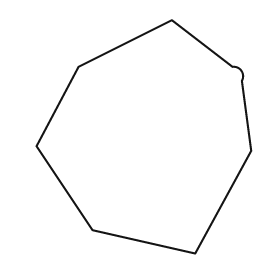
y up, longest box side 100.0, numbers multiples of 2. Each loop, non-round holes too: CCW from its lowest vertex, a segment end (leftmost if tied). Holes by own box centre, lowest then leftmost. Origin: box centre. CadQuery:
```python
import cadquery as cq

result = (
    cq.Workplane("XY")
    .moveTo(22.0, -50.0)
    .lineTo(46.0, -6.0)
    .lineTo(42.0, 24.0)
    .threePointArc((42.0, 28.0), (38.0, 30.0))
    .lineTo(12.0, 50.0)
    .lineTo(-28.0, 30.0)
    .lineTo(-46.0, -4.0)
    .lineTo(-22.0, -40.0)
    .close()
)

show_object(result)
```